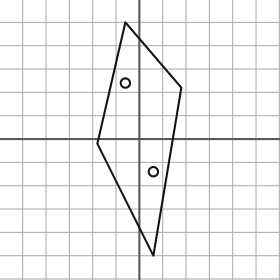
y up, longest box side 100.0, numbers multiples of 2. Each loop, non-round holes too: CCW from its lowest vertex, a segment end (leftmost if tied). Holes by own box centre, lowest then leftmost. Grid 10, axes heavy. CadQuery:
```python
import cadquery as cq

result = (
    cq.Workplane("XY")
    .moveTo(6.0, -50.0)
    .lineTo(18.0, 22.0)
    .lineTo(-6.0, 50.0)
    .lineTo(-18.0, -2.0)
    .close()
    .moveTo(6.0, -14.0)
    .circle(2.0)
    .moveTo(-6.0, 24.0)
    .circle(2.0)
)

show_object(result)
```